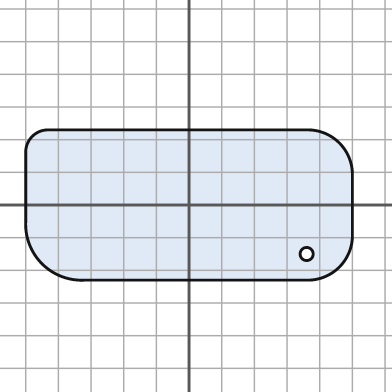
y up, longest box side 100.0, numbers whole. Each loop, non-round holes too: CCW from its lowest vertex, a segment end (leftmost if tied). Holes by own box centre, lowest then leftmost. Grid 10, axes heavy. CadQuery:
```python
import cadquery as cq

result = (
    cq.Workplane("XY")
    .moveTo(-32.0, -23.0)
    .lineTo(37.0, -23.0)
    .threePointArc((46.0, -19.0), (50.0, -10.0))
    .lineTo(50.0, 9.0)
    .threePointArc((46.0, 19.0), (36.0, 23.0))
    .lineTo(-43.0, 23.0)
    .threePointArc((-48.0, 21.0), (-50.0, 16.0))
    .lineTo(-50.0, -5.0)
    .threePointArc((-45.0, -18.0), (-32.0, -23.0))
    .close()
    .moveTo(36.0, -15.0)
    .circle(2.0)
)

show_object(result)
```